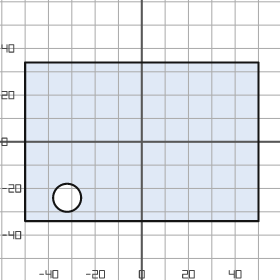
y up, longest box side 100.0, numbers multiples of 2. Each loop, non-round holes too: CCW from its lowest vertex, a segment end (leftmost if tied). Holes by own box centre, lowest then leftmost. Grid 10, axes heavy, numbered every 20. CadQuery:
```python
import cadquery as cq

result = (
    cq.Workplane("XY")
    .moveTo(-50.0, -34.0)
    .lineTo(50.0, -34.0)
    .lineTo(50.0, 34.0)
    .lineTo(-50.0, 34.0)
    .close()
    .moveTo(-32.0, -24.0)
    .circle(6.0)
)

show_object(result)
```